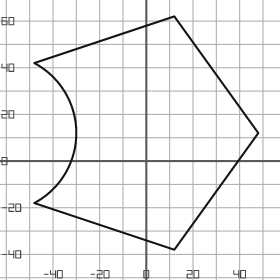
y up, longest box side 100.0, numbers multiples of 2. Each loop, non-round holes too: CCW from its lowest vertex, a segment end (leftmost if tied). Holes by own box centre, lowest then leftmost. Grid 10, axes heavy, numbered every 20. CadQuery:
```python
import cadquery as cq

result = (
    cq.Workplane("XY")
    .moveTo(12.0, -38.0)
    .lineTo(48.0, 12.0)
    .lineTo(12.0, 62.0)
    .lineTo(-48.0, 42.0)
    .threePointArc((-30.0, 12.0), (-48.0, -18.0))
    .close()
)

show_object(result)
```